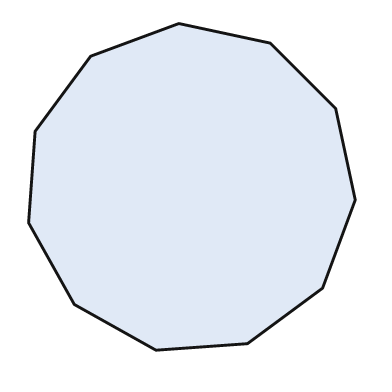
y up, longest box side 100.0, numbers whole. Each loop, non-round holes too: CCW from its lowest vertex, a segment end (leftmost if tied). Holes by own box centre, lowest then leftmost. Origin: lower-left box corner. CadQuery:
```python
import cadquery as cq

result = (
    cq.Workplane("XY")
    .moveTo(39.0, 0.0)
    .lineTo(67.0, 2.0)
    .lineTo(90.0, 19.0)
    .lineTo(100.0, 46.0)
    .lineTo(94.0, 74.0)
    .lineTo(74.0, 94.0)
    .lineTo(46.0, 100.0)
    .lineTo(19.0, 90.0)
    .lineTo(2.0, 67.0)
    .lineTo(0.0, 39.0)
    .lineTo(14.0, 14.0)
    .close()
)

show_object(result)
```